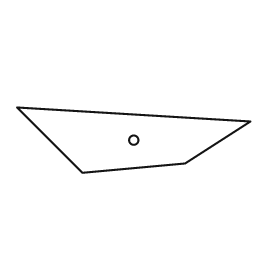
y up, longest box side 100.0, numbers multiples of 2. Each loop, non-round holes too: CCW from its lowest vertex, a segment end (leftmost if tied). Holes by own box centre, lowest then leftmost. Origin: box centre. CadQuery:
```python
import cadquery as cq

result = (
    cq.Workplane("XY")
    .moveTo(-22.0, -14.0)
    .lineTo(22.0, -10.0)
    .lineTo(50.0, 8.0)
    .lineTo(-50.0, 14.0)
    .close()
    .moveTo(0.0, 0.0)
    .circle(2.0)
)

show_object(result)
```